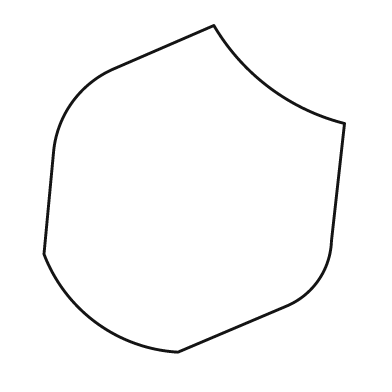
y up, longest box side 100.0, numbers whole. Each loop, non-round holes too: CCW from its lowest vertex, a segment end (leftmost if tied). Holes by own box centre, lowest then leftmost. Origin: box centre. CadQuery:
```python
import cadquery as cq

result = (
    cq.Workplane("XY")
    .moveTo(-5.0, -50.0)
    .lineTo(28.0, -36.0)
    .threePointArc((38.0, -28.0), (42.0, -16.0))
    .lineTo(46.0, 20.0)
    .threePointArc((23.0, 31.0), (6.0, 50.0))
    .lineTo(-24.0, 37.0)
    .threePointArc((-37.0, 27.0), (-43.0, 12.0))
    .lineTo(-46.0, -20.0)
    .threePointArc((-30.0, -41.0), (-5.0, -50.0))
    .close()
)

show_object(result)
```